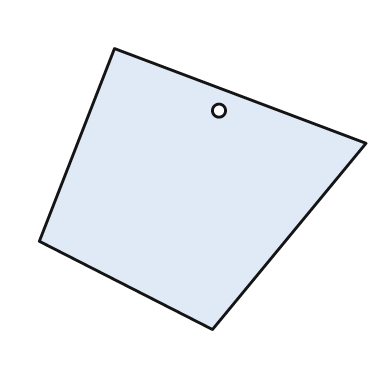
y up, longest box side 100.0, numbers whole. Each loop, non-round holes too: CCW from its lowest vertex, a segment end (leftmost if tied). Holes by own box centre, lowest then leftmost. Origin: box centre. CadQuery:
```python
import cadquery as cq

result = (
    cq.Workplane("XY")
    .moveTo(3.0, -43.0)
    .lineTo(50.0, 14.0)
    .lineTo(-27.0, 43.0)
    .lineTo(-50.0, -16.0)
    .close()
    .moveTo(5.0, 24.0)
    .circle(2.0)
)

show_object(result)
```